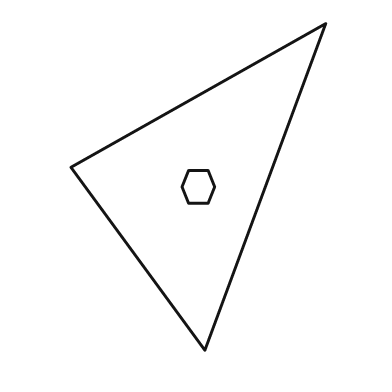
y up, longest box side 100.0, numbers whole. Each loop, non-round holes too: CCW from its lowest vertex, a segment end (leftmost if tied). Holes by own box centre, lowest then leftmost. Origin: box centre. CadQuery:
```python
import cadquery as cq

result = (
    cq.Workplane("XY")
    .moveTo(2.0, -50.0)
    .lineTo(39.0, 50.0)
    .lineTo(-39.0, 6.0)
    .close()
    .moveTo(-3.0, -5.0)
    .lineTo(3.0, -5.0)
    .lineTo(5.0, 0.0)
    .lineTo(3.0, 5.0)
    .lineTo(-3.0, 5.0)
    .lineTo(-5.0, 0.0)
    .close()
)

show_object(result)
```